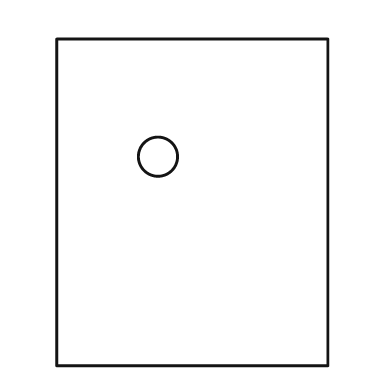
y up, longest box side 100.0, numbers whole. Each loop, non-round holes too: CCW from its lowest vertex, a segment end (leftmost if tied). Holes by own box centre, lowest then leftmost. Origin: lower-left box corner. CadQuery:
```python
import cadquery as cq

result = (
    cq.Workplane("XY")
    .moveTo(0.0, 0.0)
    .lineTo(83.0, 0.0)
    .lineTo(83.0, 100.0)
    .lineTo(0.0, 100.0)
    .close()
    .moveTo(31.0, 64.0)
    .circle(6.0)
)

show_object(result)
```